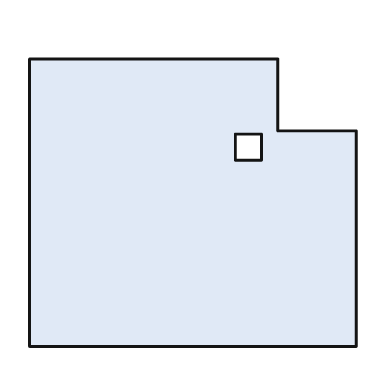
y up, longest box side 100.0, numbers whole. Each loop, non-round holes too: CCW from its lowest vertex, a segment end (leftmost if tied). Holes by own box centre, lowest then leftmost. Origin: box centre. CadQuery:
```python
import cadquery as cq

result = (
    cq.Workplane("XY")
    .moveTo(-50.0, -44.0)
    .lineTo(50.0, -44.0)
    .lineTo(50.0, 22.0)
    .lineTo(26.0, 22.0)
    .lineTo(26.0, 44.0)
    .lineTo(-50.0, 44.0)
    .close()
    .moveTo(13.0, 13.0)
    .lineTo(21.0, 13.0)
    .lineTo(21.0, 21.0)
    .lineTo(13.0, 21.0)
    .close()
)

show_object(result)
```